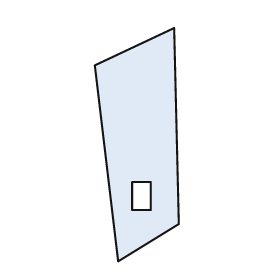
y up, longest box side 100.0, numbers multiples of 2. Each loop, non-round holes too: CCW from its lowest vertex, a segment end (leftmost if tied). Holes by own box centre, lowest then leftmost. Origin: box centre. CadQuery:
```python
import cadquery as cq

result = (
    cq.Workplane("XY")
    .moveTo(-8.0, -50.0)
    .lineTo(18.0, -34.0)
    .lineTo(16.0, 50.0)
    .lineTo(-18.0, 34.0)
    .close()
    .moveTo(-2.0, -28.0)
    .lineTo(6.0, -28.0)
    .lineTo(6.0, -16.0)
    .lineTo(-2.0, -16.0)
    .close()
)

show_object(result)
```